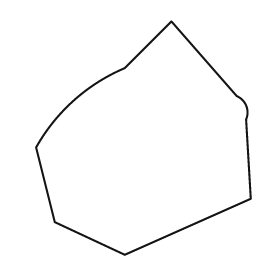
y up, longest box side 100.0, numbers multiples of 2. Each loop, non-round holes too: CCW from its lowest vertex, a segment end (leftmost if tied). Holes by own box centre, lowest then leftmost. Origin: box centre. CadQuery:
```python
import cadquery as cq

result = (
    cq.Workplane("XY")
    .moveTo(-8.0, -50.0)
    .lineTo(46.0, -26.0)
    .lineTo(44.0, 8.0)
    .threePointArc((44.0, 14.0), (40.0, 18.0))
    .lineTo(12.0, 50.0)
    .lineTo(-8.0, 30.0)
    .threePointArc((-30.0, 16.0), (-46.0, -4.0))
    .lineTo(-38.0, -36.0)
    .close()
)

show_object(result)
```